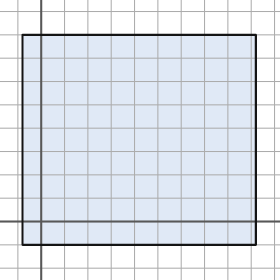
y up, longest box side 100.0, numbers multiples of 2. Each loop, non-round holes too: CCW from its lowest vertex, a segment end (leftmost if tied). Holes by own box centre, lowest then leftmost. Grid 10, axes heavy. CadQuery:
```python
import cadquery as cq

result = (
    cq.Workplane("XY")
    .moveTo(-8.0, -10.0)
    .lineTo(92.0, -10.0)
    .lineTo(92.0, 80.0)
    .lineTo(-8.0, 80.0)
    .close()
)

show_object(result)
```